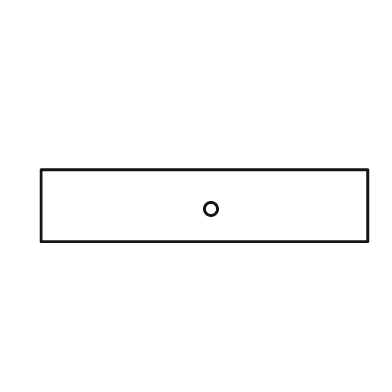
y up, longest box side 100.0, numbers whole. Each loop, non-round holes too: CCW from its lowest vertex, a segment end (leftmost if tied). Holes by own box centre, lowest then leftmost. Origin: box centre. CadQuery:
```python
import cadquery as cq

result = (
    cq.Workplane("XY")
    .moveTo(-50.0, -11.0)
    .lineTo(50.0, -11.0)
    .lineTo(50.0, 11.0)
    .lineTo(-50.0, 11.0)
    .close()
    .moveTo(2.0, -1.0)
    .circle(2.0)
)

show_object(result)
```